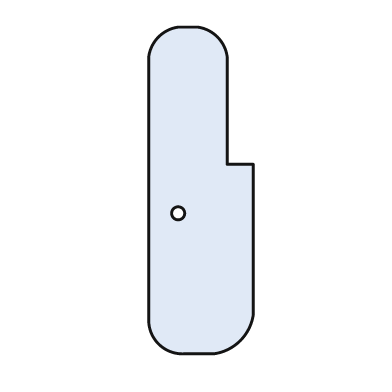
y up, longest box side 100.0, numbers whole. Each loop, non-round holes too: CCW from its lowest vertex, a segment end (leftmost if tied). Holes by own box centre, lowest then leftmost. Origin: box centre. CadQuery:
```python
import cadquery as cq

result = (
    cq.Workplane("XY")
    .moveTo(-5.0, -50.0)
    .lineTo(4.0, -50.0)
    .threePointArc((12.0, -46.0), (16.0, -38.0))
    .lineTo(16.0, 8.0)
    .lineTo(8.0, 8.0)
    .lineTo(8.0, 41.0)
    .threePointArc((5.0, 47.0), (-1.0, 50.0))
    .lineTo(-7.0, 50.0)
    .threePointArc((-13.0, 47.0), (-16.0, 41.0))
    .lineTo(-16.0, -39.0)
    .threePointArc((-13.0, -47.0), (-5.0, -50.0))
    .close()
    .moveTo(-7.0, -7.0)
    .circle(2.0)
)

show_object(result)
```